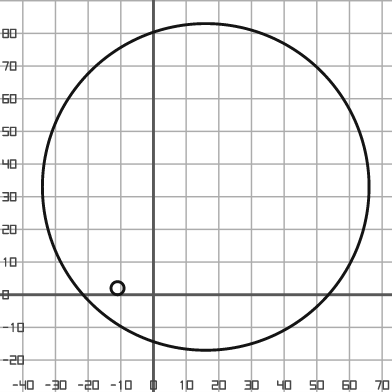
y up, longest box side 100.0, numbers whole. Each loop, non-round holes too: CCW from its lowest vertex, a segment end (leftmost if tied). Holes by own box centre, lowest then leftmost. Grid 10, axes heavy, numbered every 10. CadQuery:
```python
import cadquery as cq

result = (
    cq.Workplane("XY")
    .moveTo(16.0, 33.0)
    .circle(50.0)
    .moveTo(-11.0, 2.0)
    .circle(2.0)
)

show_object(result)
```